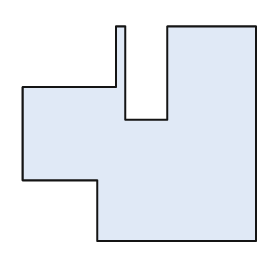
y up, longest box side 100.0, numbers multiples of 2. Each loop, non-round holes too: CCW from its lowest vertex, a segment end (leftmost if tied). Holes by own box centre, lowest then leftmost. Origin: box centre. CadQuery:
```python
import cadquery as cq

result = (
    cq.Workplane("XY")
    .moveTo(-18.0, -46.0)
    .lineTo(50.0, -46.0)
    .lineTo(50.0, 46.0)
    .lineTo(12.0, 46.0)
    .lineTo(12.0, 6.0)
    .lineTo(-6.0, 6.0)
    .lineTo(-6.0, 46.0)
    .lineTo(-10.0, 46.0)
    .lineTo(-10.0, 20.0)
    .lineTo(-50.0, 20.0)
    .lineTo(-50.0, -20.0)
    .lineTo(-18.0, -20.0)
    .close()
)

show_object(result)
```